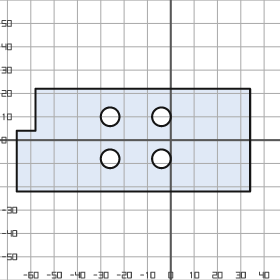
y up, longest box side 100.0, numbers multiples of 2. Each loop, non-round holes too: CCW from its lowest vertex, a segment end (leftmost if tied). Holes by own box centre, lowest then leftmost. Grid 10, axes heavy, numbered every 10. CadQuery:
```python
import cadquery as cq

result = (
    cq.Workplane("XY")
    .moveTo(-66.0, -22.0)
    .lineTo(34.0, -22.0)
    .lineTo(34.0, 22.0)
    .lineTo(-58.0, 22.0)
    .lineTo(-58.0, 4.0)
    .lineTo(-66.0, 4.0)
    .close()
    .moveTo(-26.0, -8.0)
    .circle(4.0)
    .moveTo(-4.0, -8.0)
    .circle(4.0)
    .moveTo(-26.0, 10.0)
    .circle(4.0)
    .moveTo(-4.0, 10.0)
    .circle(4.0)
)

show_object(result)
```